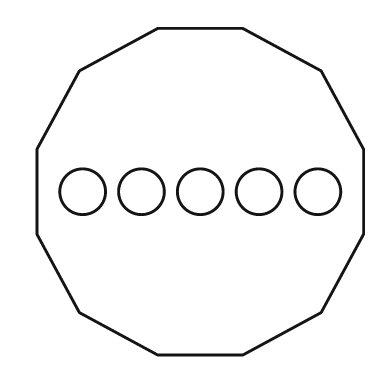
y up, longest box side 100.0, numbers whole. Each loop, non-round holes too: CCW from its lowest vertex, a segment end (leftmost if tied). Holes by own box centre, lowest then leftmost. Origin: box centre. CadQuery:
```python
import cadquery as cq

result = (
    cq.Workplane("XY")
    .moveTo(-13.0, -50.0)
    .lineTo(13.0, -50.0)
    .lineTo(37.0, -37.0)
    .lineTo(50.0, -13.0)
    .lineTo(50.0, 13.0)
    .lineTo(37.0, 37.0)
    .lineTo(13.0, 50.0)
    .lineTo(-13.0, 50.0)
    .lineTo(-37.0, 37.0)
    .lineTo(-50.0, 13.0)
    .lineTo(-50.0, -13.0)
    .lineTo(-37.0, -37.0)
    .close()
    .moveTo(-36.0, 0.0)
    .circle(7.0)
    .moveTo(-18.0, 0.0)
    .circle(7.0)
    .moveTo(0.0, 0.0)
    .circle(7.0)
    .moveTo(18.0, 0.0)
    .circle(7.0)
    .moveTo(36.0, 0.0)
    .circle(7.0)
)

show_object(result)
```